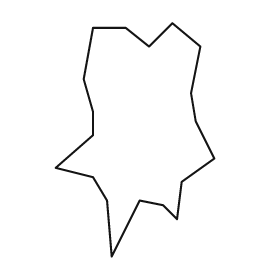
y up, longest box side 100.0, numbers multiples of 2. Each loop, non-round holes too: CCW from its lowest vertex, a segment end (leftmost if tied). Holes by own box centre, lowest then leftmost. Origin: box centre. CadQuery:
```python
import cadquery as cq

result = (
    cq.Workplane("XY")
    .moveTo(-10.0, -50.0)
    .lineTo(2.0, -26.0)
    .lineTo(12.0, -28.0)
    .lineTo(18.0, -34.0)
    .lineTo(20.0, -18.0)
    .lineTo(34.0, -8.0)
    .lineTo(26.0, 8.0)
    .lineTo(24.0, 20.0)
    .lineTo(28.0, 40.0)
    .lineTo(16.0, 50.0)
    .lineTo(6.0, 40.0)
    .lineTo(-4.0, 48.0)
    .lineTo(-18.0, 48.0)
    .lineTo(-22.0, 26.0)
    .lineTo(-18.0, 12.0)
    .lineTo(-18.0, 2.0)
    .lineTo(-34.0, -12.0)
    .lineTo(-18.0, -16.0)
    .lineTo(-12.0, -26.0)
    .close()
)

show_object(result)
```